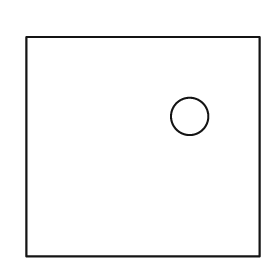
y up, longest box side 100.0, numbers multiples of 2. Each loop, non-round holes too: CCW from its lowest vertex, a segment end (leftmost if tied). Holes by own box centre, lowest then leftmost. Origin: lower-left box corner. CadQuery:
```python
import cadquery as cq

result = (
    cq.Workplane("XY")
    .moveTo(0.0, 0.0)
    .lineTo(100.0, 0.0)
    .lineTo(100.0, 94.0)
    .lineTo(0.0, 94.0)
    .close()
    .moveTo(70.0, 60.0)
    .circle(8.0)
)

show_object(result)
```